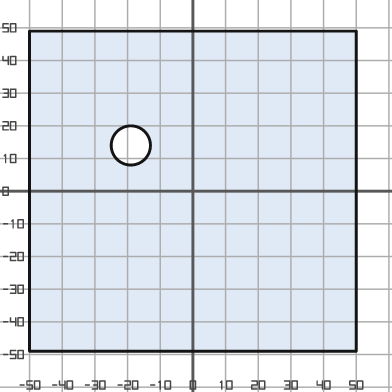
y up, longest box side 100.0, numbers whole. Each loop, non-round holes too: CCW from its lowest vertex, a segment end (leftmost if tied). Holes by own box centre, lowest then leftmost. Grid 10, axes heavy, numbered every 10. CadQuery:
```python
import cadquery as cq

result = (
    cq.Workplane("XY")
    .moveTo(-50.0, -49.0)
    .lineTo(50.0, -49.0)
    .lineTo(50.0, 49.0)
    .lineTo(-50.0, 49.0)
    .close()
    .moveTo(-19.0, 14.0)
    .circle(6.0)
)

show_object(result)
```